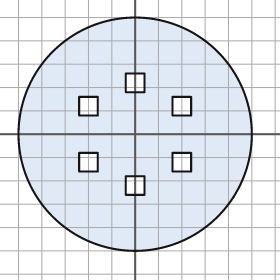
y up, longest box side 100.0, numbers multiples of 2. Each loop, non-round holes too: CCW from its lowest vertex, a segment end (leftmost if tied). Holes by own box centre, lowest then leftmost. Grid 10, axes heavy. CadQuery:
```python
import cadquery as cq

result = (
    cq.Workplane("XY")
    .moveTo(0.0, 0.0)
    .circle(50.0)
    .moveTo(-4.0, -26.0)
    .lineTo(4.0, -26.0)
    .lineTo(4.0, -18.0)
    .lineTo(-4.0, -18.0)
    .close()
    .moveTo(-24.0, -16.0)
    .lineTo(-16.0, -16.0)
    .lineTo(-16.0, -8.0)
    .lineTo(-24.0, -8.0)
    .close()
    .moveTo(16.0, -16.0)
    .lineTo(24.0, -16.0)
    .lineTo(24.0, -8.0)
    .lineTo(16.0, -8.0)
    .close()
    .moveTo(-24.0, 8.0)
    .lineTo(-16.0, 8.0)
    .lineTo(-16.0, 16.0)
    .lineTo(-24.0, 16.0)
    .close()
    .moveTo(16.0, 8.0)
    .lineTo(24.0, 8.0)
    .lineTo(24.0, 16.0)
    .lineTo(16.0, 16.0)
    .close()
    .moveTo(-4.0, 18.0)
    .lineTo(4.0, 18.0)
    .lineTo(4.0, 26.0)
    .lineTo(-4.0, 26.0)
    .close()
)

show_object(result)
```